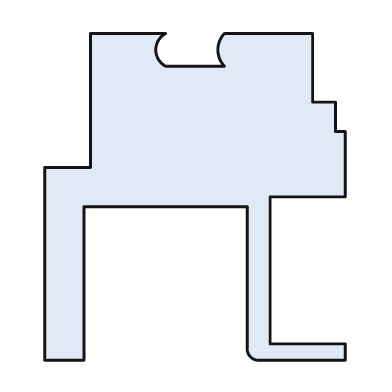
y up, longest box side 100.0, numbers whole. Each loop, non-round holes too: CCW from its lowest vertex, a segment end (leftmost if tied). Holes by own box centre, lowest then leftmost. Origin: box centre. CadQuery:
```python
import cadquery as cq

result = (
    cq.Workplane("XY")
    .moveTo(-46.0, -50.0)
    .lineTo(-34.0, -50.0)
    .lineTo(-34.0, -3.0)
    .lineTo(16.0, -3.0)
    .lineTo(16.0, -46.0)
    .threePointArc((17.0, -49.0), (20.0, -50.0))
    .lineTo(46.0, -50.0)
    .lineTo(46.0, -45.0)
    .lineTo(23.0, -45.0)
    .lineTo(23.0, 0.0)
    .lineTo(46.0, 0.0)
    .lineTo(46.0, 20.0)
    .lineTo(43.0, 20.0)
    .lineTo(43.0, 29.0)
    .lineTo(36.0, 29.0)
    .lineTo(36.0, 50.0)
    .lineTo(9.0, 50.0)
    .threePointArc((7.0, 45.0), (9.0, 40.0))
    .lineTo(-9.0, 40.0)
    .threePointArc((-12.0, 45.0), (-9.0, 50.0))
    .lineTo(-32.0, 50.0)
    .lineTo(-32.0, 9.0)
    .lineTo(-46.0, 9.0)
    .close()
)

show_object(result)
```